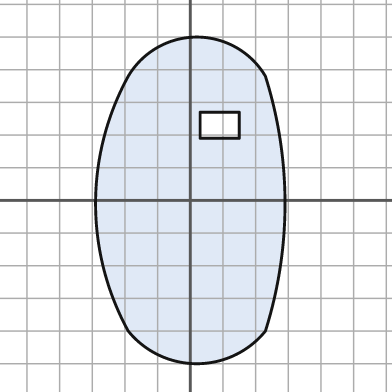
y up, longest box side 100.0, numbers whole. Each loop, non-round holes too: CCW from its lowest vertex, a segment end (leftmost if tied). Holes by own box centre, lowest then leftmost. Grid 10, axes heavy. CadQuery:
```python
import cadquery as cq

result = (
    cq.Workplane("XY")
    .moveTo(-19.0, -40.0)
    .threePointArc((2.0, -50.0), (23.0, -40.0))
    .threePointArc((29.0, -1.0), (23.0, 38.0))
    .threePointArc((2.0, 50.0), (-19.0, 38.0))
    .threePointArc((-29.0, -1.0), (-19.0, -40.0))
    .close()
    .moveTo(3.0, 19.0)
    .lineTo(15.0, 19.0)
    .lineTo(15.0, 27.0)
    .lineTo(3.0, 27.0)
    .close()
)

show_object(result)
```